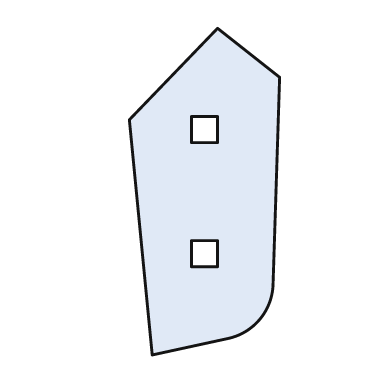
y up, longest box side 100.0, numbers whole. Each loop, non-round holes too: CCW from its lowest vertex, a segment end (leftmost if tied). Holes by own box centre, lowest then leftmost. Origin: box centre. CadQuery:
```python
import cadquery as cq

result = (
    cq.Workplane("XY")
    .moveTo(-16.0, -50.0)
    .lineTo(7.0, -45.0)
    .threePointArc((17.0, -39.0), (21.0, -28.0))
    .lineTo(23.0, 35.0)
    .lineTo(4.0, 50.0)
    .lineTo(-23.0, 22.0)
    .close()
    .moveTo(-4.0, -23.0)
    .lineTo(4.0, -23.0)
    .lineTo(4.0, -15.0)
    .lineTo(-4.0, -15.0)
    .close()
    .moveTo(-4.0, 15.0)
    .lineTo(4.0, 15.0)
    .lineTo(4.0, 23.0)
    .lineTo(-4.0, 23.0)
    .close()
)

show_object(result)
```